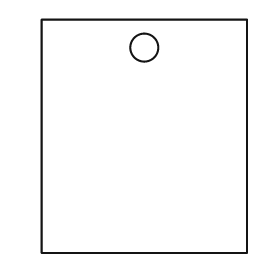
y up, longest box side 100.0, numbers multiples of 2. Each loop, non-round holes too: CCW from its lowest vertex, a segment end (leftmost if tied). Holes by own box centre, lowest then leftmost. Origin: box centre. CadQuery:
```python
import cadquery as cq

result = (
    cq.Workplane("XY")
    .moveTo(-44.0, -50.0)
    .lineTo(44.0, -50.0)
    .lineTo(44.0, 50.0)
    .lineTo(-44.0, 50.0)
    .close()
    .moveTo(0.0, 38.0)
    .circle(6.0)
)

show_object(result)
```